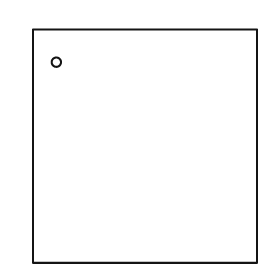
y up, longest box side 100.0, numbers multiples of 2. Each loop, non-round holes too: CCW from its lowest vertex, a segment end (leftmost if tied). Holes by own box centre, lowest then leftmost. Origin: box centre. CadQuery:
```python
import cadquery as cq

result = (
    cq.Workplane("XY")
    .moveTo(-48.0, -50.0)
    .lineTo(48.0, -50.0)
    .lineTo(48.0, 50.0)
    .lineTo(-48.0, 50.0)
    .close()
    .moveTo(-38.0, 36.0)
    .circle(2.0)
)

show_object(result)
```